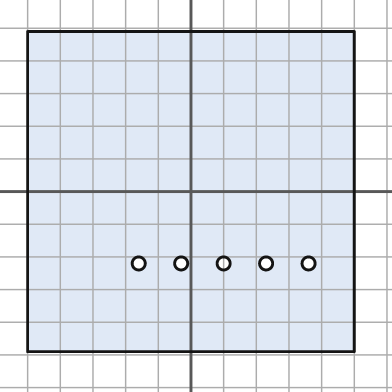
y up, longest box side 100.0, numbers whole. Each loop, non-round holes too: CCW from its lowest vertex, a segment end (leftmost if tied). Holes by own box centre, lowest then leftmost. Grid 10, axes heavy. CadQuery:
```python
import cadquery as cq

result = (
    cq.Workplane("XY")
    .moveTo(-50.0, -49.0)
    .lineTo(50.0, -49.0)
    .lineTo(50.0, 49.0)
    .lineTo(-50.0, 49.0)
    .close()
    .moveTo(-16.0, -22.0)
    .circle(2.0)
    .moveTo(-3.0, -22.0)
    .circle(2.0)
    .moveTo(10.0, -22.0)
    .circle(2.0)
    .moveTo(23.0, -22.0)
    .circle(2.0)
    .moveTo(36.0, -22.0)
    .circle(2.0)
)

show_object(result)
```